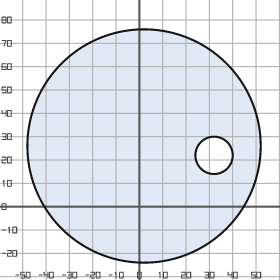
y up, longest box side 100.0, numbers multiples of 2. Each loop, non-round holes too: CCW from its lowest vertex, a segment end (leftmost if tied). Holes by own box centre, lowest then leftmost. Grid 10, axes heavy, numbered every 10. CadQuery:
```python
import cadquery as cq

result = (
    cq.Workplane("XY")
    .moveTo(2.0, 26.0)
    .circle(50.0)
    .moveTo(32.0, 22.0)
    .circle(8.0)
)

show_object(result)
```